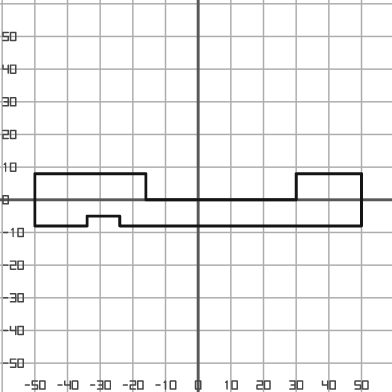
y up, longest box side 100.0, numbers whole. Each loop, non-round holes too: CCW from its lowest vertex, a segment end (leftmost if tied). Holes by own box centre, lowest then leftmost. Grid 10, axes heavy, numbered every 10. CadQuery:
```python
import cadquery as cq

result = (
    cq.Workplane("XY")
    .moveTo(-50.0, -8.0)
    .lineTo(-34.0, -8.0)
    .lineTo(-34.0, -5.0)
    .lineTo(-24.0, -5.0)
    .lineTo(-24.0, -8.0)
    .lineTo(50.0, -8.0)
    .lineTo(50.0, 8.0)
    .lineTo(30.0, 8.0)
    .lineTo(30.0, 0.0)
    .lineTo(-16.0, 0.0)
    .lineTo(-16.0, 8.0)
    .lineTo(-50.0, 8.0)
    .close()
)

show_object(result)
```